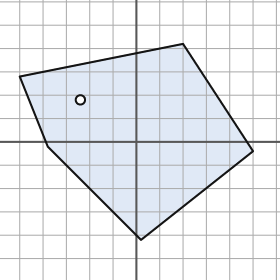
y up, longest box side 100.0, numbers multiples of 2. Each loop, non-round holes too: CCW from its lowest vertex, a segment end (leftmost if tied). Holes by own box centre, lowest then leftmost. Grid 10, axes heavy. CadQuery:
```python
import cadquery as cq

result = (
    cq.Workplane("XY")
    .moveTo(2.0, -42.0)
    .lineTo(50.0, -4.0)
    .lineTo(20.0, 42.0)
    .lineTo(-50.0, 28.0)
    .lineTo(-38.0, -2.0)
    .close()
    .moveTo(-24.0, 18.0)
    .circle(2.0)
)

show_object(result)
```